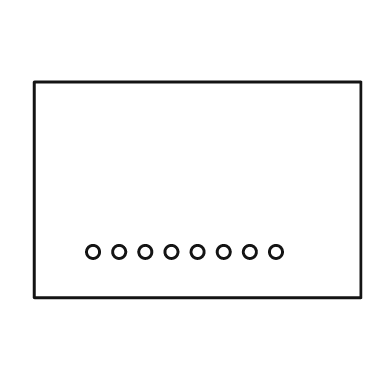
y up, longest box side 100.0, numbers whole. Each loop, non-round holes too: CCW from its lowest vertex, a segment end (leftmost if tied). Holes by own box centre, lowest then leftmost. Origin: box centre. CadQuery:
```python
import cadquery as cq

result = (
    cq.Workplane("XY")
    .moveTo(-50.0, -33.0)
    .lineTo(50.0, -33.0)
    .lineTo(50.0, 33.0)
    .lineTo(-50.0, 33.0)
    .close()
    .moveTo(-32.0, -19.0)
    .circle(2.0)
    .moveTo(-24.0, -19.0)
    .circle(2.0)
    .moveTo(-16.0, -19.0)
    .circle(2.0)
    .moveTo(-8.0, -19.0)
    .circle(2.0)
    .moveTo(0.0, -19.0)
    .circle(2.0)
    .moveTo(8.0, -19.0)
    .circle(2.0)
    .moveTo(16.0, -19.0)
    .circle(2.0)
    .moveTo(24.0, -19.0)
    .circle(2.0)
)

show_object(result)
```